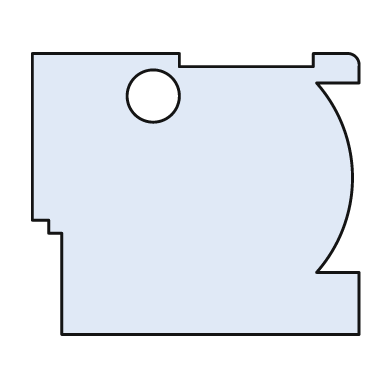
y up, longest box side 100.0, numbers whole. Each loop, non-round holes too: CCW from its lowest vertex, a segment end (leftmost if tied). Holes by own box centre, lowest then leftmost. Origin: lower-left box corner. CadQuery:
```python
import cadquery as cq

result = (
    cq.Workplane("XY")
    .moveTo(9.0, 0.0)
    .lineTo(100.0, 0.0)
    .lineTo(100.0, 19.0)
    .lineTo(87.0, 19.0)
    .threePointArc((98.0, 48.0), (87.0, 77.0))
    .lineTo(100.0, 77.0)
    .lineTo(100.0, 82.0)
    .threePointArc((99.0, 85.0), (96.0, 86.0))
    .lineTo(86.0, 86.0)
    .lineTo(86.0, 82.0)
    .lineTo(45.0, 82.0)
    .lineTo(45.0, 86.0)
    .lineTo(0.0, 86.0)
    .lineTo(0.0, 35.0)
    .lineTo(5.0, 35.0)
    .lineTo(5.0, 31.0)
    .lineTo(9.0, 31.0)
    .close()
    .moveTo(37.0, 73.0)
    .circle(8.0)
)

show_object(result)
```